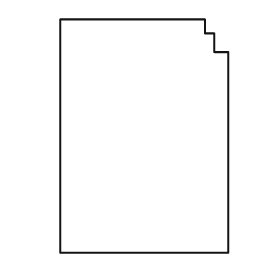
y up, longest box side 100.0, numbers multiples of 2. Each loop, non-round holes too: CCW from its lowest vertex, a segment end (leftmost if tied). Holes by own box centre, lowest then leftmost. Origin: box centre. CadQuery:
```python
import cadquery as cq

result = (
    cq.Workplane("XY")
    .moveTo(-36.0, -50.0)
    .lineTo(36.0, -50.0)
    .lineTo(36.0, 36.0)
    .lineTo(30.0, 36.0)
    .lineTo(30.0, 44.0)
    .lineTo(26.0, 44.0)
    .lineTo(26.0, 50.0)
    .lineTo(-36.0, 50.0)
    .close()
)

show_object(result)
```